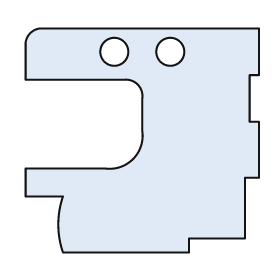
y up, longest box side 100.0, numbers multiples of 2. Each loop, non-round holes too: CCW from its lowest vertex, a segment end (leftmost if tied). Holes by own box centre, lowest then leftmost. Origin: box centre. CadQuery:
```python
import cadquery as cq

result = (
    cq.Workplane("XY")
    .moveTo(-34.0, -48.0)
    .lineTo(20.0, -48.0)
    .lineTo(20.0, -42.0)
    .lineTo(44.0, -42.0)
    .lineTo(44.0, -16.0)
    .lineTo(50.0, -16.0)
    .lineTo(50.0, 8.0)
    .lineTo(46.0, 8.0)
    .lineTo(46.0, 28.0)
    .lineTo(50.0, 28.0)
    .lineTo(50.0, 48.0)
    .lineTo(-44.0, 48.0)
    .threePointArc((-48.0, 46.0), (-50.0, 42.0))
    .lineTo(-50.0, 26.0)
    .lineTo(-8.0, 26.0)
    .threePointArc((-2.0, 24.0), (0.0, 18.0))
    .lineTo(0.0, 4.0)
    .threePointArc((-4.0, -8.0), (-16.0, -12.0))
    .lineTo(-50.0, -12.0)
    .lineTo(-50.0, -24.0)
    .lineTo(-34.0, -24.0)
    .threePointArc((-36.0, -36.0), (-34.0, -48.0))
    .close()
    .moveTo(-12.0, 38.0)
    .circle(6.0)
    .moveTo(12.0, 38.0)
    .circle(6.0)
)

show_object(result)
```